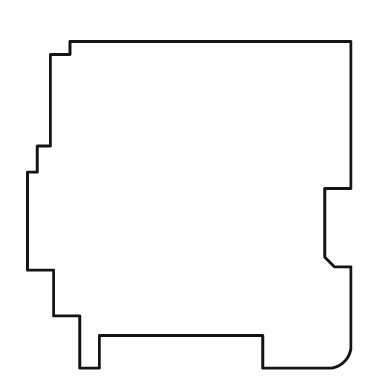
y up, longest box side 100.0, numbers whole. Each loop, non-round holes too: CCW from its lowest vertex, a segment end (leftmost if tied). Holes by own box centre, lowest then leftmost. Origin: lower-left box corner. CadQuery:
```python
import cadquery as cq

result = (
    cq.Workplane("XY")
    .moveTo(16.0, 0.0)
    .lineTo(22.0, 0.0)
    .lineTo(22.0, 10.0)
    .lineTo(72.0, 10.0)
    .lineTo(72.0, 0.0)
    .lineTo(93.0, 0.0)
    .threePointArc((97.0, 2.0), (99.0, 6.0))
    .lineTo(99.0, 31.0)
    .lineTo(94.0, 31.0)
    .lineTo(91.0, 34.0)
    .lineTo(91.0, 55.0)
    .lineTo(99.0, 55.0)
    .lineTo(99.0, 100.0)
    .lineTo(13.0, 100.0)
    .lineTo(13.0, 96.0)
    .lineTo(7.0, 96.0)
    .lineTo(7.0, 68.0)
    .lineTo(3.0, 68.0)
    .lineTo(3.0, 60.0)
    .lineTo(0.0, 60.0)
    .lineTo(0.0, 30.0)
    .lineTo(8.0, 30.0)
    .lineTo(8.0, 16.0)
    .lineTo(16.0, 16.0)
    .close()
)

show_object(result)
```